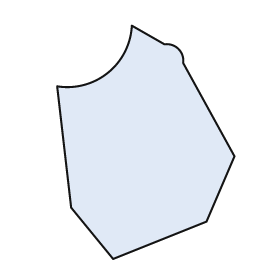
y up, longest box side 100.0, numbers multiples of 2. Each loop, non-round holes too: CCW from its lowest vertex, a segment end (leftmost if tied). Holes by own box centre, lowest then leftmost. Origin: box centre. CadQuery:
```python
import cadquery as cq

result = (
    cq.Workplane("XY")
    .moveTo(-14.0, -50.0)
    .lineTo(26.0, -34.0)
    .lineTo(38.0, -6.0)
    .lineTo(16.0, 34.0)
    .threePointArc((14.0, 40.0), (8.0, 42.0))
    .lineTo(-6.0, 50.0)
    .threePointArc((-16.0, 30.0), (-38.0, 24.0))
    .lineTo(-32.0, -28.0)
    .close()
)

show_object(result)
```